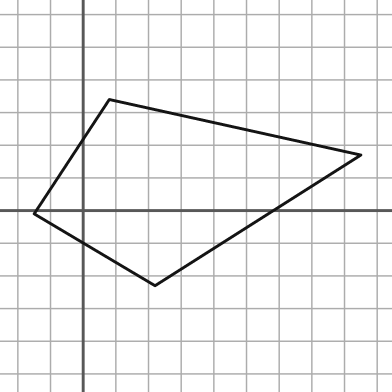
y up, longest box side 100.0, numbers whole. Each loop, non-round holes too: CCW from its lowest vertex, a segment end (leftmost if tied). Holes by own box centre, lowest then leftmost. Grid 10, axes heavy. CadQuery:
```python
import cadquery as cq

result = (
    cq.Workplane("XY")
    .moveTo(22.0, -23.0)
    .lineTo(85.0, 17.0)
    .lineTo(8.0, 34.0)
    .lineTo(-15.0, -1.0)
    .close()
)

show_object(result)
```